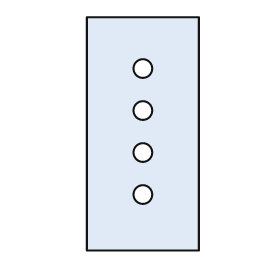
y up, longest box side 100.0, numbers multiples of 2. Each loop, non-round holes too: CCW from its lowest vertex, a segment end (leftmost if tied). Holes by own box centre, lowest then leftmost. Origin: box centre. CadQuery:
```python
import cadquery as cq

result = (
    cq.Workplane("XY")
    .moveTo(-24.0, -50.0)
    .lineTo(24.0, -50.0)
    .lineTo(24.0, 50.0)
    .lineTo(-24.0, 50.0)
    .close()
    .moveTo(0.0, -26.0)
    .circle(4.0)
    .moveTo(0.0, -8.0)
    .circle(4.0)
    .moveTo(0.0, 10.0)
    .circle(4.0)
    .moveTo(0.0, 28.0)
    .circle(4.0)
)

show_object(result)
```